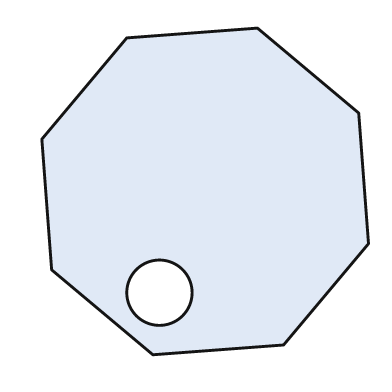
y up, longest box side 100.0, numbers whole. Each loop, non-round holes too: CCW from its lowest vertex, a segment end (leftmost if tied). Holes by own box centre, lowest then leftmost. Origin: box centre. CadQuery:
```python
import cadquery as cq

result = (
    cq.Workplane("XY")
    .moveTo(-16.0, -50.0)
    .lineTo(24.0, -47.0)
    .lineTo(50.0, -16.0)
    .lineTo(47.0, 24.0)
    .lineTo(16.0, 50.0)
    .lineTo(-24.0, 47.0)
    .lineTo(-50.0, 16.0)
    .lineTo(-47.0, -24.0)
    .close()
    .moveTo(-14.0, -31.0)
    .circle(10.0)
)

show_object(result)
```